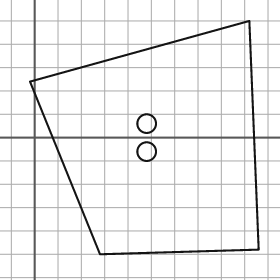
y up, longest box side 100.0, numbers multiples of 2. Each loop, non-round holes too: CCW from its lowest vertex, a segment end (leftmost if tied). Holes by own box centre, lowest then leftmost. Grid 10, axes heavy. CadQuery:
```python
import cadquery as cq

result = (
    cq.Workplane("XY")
    .moveTo(28.0, -50.0)
    .lineTo(96.0, -48.0)
    .lineTo(92.0, 50.0)
    .lineTo(-2.0, 24.0)
    .close()
    .moveTo(48.0, -6.0)
    .circle(4.0)
    .moveTo(48.0, 6.0)
    .circle(4.0)
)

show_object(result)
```